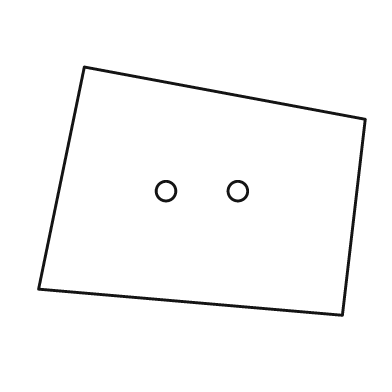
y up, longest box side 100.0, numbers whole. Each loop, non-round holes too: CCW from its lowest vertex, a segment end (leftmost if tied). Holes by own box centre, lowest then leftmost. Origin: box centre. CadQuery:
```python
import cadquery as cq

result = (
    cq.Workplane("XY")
    .moveTo(43.0, -38.0)
    .lineTo(50.0, 22.0)
    .lineTo(-36.0, 38.0)
    .lineTo(-50.0, -30.0)
    .close()
    .moveTo(-11.0, 0.0)
    .circle(3.0)
    .moveTo(11.0, 0.0)
    .circle(3.0)
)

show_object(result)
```